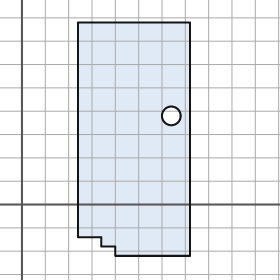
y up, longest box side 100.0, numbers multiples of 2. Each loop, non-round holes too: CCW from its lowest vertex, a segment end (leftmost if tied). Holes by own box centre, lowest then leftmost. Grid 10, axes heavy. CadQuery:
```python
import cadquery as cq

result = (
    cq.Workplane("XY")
    .moveTo(40.0, -22.0)
    .lineTo(72.0, -22.0)
    .lineTo(72.0, 78.0)
    .lineTo(24.0, 78.0)
    .lineTo(24.0, -14.0)
    .lineTo(34.0, -14.0)
    .lineTo(34.0, -18.0)
    .lineTo(40.0, -18.0)
    .close()
    .moveTo(64.0, 38.0)
    .circle(4.0)
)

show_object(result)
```